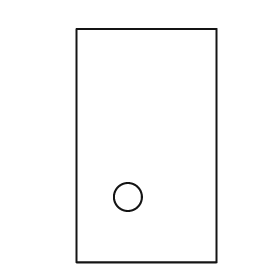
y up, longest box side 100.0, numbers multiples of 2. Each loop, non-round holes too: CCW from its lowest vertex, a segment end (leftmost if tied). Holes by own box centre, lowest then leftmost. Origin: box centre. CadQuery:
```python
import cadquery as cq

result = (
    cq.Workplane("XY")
    .moveTo(-30.0, -50.0)
    .lineTo(30.0, -50.0)
    .lineTo(30.0, 50.0)
    .lineTo(-30.0, 50.0)
    .close()
    .moveTo(-8.0, -22.0)
    .circle(6.0)
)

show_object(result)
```